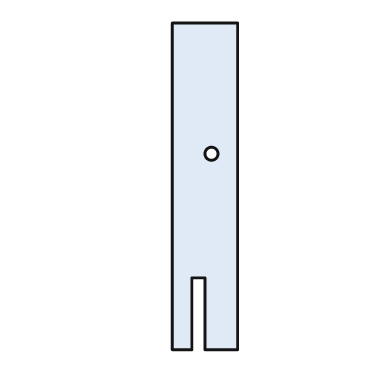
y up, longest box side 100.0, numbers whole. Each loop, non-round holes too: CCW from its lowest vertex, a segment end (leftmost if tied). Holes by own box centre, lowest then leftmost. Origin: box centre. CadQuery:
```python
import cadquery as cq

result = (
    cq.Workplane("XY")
    .moveTo(-10.0, -50.0)
    .lineTo(-4.0, -50.0)
    .lineTo(-4.0, -28.0)
    .lineTo(0.0, -28.0)
    .lineTo(0.0, -50.0)
    .lineTo(10.0, -50.0)
    .lineTo(10.0, 50.0)
    .lineTo(-10.0, 50.0)
    .close()
    .moveTo(2.0, 10.0)
    .circle(2.0)
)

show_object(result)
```